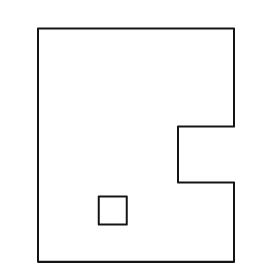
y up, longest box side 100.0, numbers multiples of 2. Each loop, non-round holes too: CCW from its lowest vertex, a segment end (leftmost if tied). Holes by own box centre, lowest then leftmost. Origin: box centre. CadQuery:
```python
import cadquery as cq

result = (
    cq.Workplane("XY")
    .moveTo(-42.0, -50.0)
    .lineTo(42.0, -50.0)
    .lineTo(42.0, -16.0)
    .lineTo(18.0, -16.0)
    .lineTo(18.0, 8.0)
    .lineTo(42.0, 8.0)
    .lineTo(42.0, 50.0)
    .lineTo(-42.0, 50.0)
    .close()
    .moveTo(-16.0, -34.0)
    .lineTo(-4.0, -34.0)
    .lineTo(-4.0, -22.0)
    .lineTo(-16.0, -22.0)
    .close()
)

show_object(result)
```